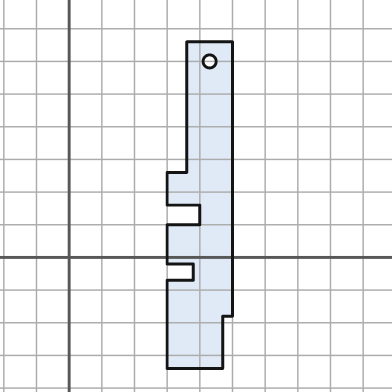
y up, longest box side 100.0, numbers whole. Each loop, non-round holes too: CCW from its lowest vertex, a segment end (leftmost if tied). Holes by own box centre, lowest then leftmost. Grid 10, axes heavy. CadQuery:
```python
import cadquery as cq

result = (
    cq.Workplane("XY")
    .moveTo(30.0, -34.0)
    .lineTo(47.0, -34.0)
    .lineTo(47.0, -18.0)
    .lineTo(50.0, -18.0)
    .lineTo(50.0, 66.0)
    .lineTo(36.0, 66.0)
    .lineTo(36.0, 26.0)
    .lineTo(30.0, 26.0)
    .lineTo(30.0, 16.0)
    .lineTo(40.0, 16.0)
    .lineTo(40.0, 10.0)
    .lineTo(30.0, 10.0)
    .lineTo(30.0, -2.0)
    .lineTo(38.0, -2.0)
    .lineTo(38.0, -7.0)
    .lineTo(30.0, -7.0)
    .close()
    .moveTo(43.0, 60.0)
    .circle(2.0)
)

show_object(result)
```